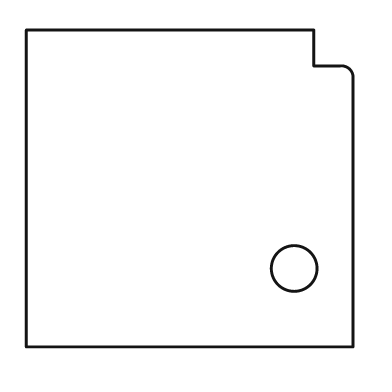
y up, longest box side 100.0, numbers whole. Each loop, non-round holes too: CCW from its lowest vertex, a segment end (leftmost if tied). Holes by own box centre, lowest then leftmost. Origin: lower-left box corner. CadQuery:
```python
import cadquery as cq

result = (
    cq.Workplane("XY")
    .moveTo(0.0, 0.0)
    .lineTo(100.0, 0.0)
    .lineTo(100.0, 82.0)
    .threePointArc((99.0, 85.0), (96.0, 86.0))
    .lineTo(88.0, 86.0)
    .lineTo(88.0, 97.0)
    .lineTo(0.0, 97.0)
    .close()
    .moveTo(82.0, 24.0)
    .circle(7.0)
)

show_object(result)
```